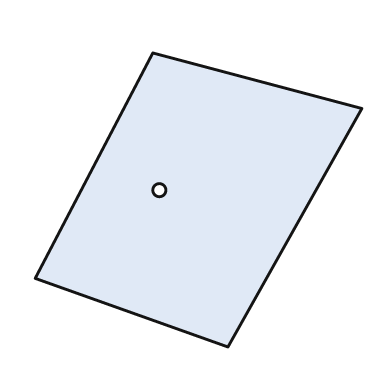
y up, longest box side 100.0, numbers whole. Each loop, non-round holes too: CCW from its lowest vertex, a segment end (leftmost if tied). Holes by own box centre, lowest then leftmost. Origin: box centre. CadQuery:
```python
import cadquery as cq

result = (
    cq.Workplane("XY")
    .moveTo(9.0, -45.0)
    .lineTo(50.0, 28.0)
    .lineTo(-14.0, 45.0)
    .lineTo(-50.0, -24.0)
    .close()
    .moveTo(-12.0, 3.0)
    .circle(2.0)
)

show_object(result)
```